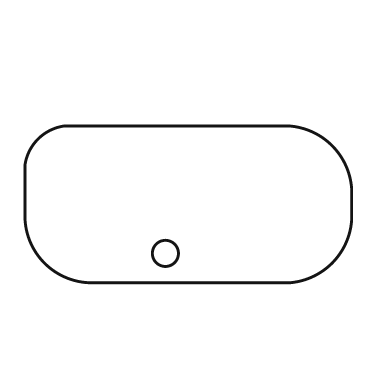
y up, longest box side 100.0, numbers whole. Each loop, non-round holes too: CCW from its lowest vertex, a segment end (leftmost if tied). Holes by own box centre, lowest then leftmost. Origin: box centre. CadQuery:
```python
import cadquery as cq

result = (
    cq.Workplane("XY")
    .moveTo(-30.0, -24.0)
    .lineTo(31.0, -24.0)
    .threePointArc((44.0, -18.0), (50.0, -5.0))
    .lineTo(50.0, 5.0)
    .threePointArc((44.0, 18.0), (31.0, 24.0))
    .lineTo(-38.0, 24.0)
    .threePointArc((-46.0, 20.0), (-50.0, 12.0))
    .lineTo(-50.0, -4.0)
    .threePointArc((-44.0, -18.0), (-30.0, -24.0))
    .close()
    .moveTo(-7.0, -15.0)
    .circle(4.0)
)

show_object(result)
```